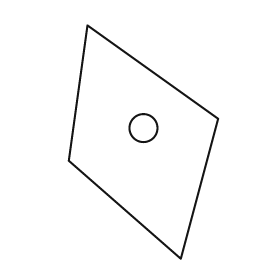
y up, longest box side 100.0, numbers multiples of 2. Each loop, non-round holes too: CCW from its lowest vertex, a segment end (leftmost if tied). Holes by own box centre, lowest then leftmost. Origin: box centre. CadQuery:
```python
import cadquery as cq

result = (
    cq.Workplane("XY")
    .moveTo(16.0, -50.0)
    .lineTo(32.0, 10.0)
    .lineTo(-24.0, 50.0)
    .lineTo(-32.0, -8.0)
    .close()
    .moveTo(0.0, 6.0)
    .circle(6.0)
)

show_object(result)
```